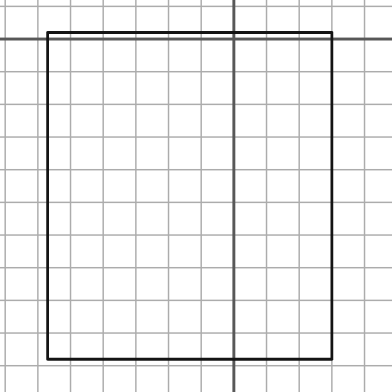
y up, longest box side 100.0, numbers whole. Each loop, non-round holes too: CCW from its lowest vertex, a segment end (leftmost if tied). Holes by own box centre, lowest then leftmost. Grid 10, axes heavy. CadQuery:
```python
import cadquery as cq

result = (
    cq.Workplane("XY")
    .moveTo(-57.0, -98.0)
    .lineTo(30.0, -98.0)
    .lineTo(30.0, 2.0)
    .lineTo(-57.0, 2.0)
    .close()
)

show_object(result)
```